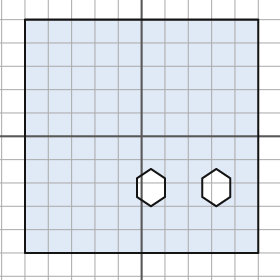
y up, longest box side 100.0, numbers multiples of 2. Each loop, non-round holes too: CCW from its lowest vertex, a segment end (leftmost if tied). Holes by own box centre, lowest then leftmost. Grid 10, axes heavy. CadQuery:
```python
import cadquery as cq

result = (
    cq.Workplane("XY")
    .moveTo(-50.0, -50.0)
    .lineTo(50.0, -50.0)
    .lineTo(50.0, 50.0)
    .lineTo(-50.0, 50.0)
    .close()
    .moveTo(4.0, -30.0)
    .lineTo(10.0, -26.0)
    .lineTo(10.0, -18.0)
    .lineTo(4.0, -14.0)
    .lineTo(-2.0, -18.0)
    .lineTo(-2.0, -26.0)
    .close()
    .moveTo(32.0, -30.0)
    .lineTo(38.0, -26.0)
    .lineTo(38.0, -18.0)
    .lineTo(32.0, -14.0)
    .lineTo(26.0, -18.0)
    .lineTo(26.0, -26.0)
    .close()
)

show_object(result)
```